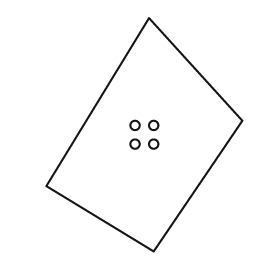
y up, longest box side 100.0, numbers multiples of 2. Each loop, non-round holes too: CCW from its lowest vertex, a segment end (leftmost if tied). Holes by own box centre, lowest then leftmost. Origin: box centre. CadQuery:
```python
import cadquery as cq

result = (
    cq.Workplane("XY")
    .moveTo(4.0, -50.0)
    .lineTo(42.0, 6.0)
    .lineTo(2.0, 50.0)
    .lineTo(-42.0, -22.0)
    .close()
    .moveTo(-4.0, -4.0)
    .circle(2.0)
    .moveTo(4.0, -4.0)
    .circle(2.0)
    .moveTo(-4.0, 4.0)
    .circle(2.0)
    .moveTo(4.0, 4.0)
    .circle(2.0)
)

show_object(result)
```